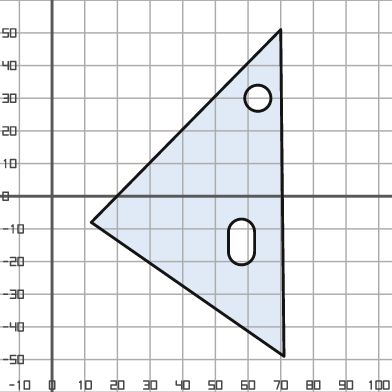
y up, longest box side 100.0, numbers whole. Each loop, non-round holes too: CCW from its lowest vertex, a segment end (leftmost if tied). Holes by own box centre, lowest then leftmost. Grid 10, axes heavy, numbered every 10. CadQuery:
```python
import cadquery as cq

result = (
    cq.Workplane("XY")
    .moveTo(71.0, -49.0)
    .lineTo(70.0, 51.0)
    .lineTo(12.0, -8.0)
    .close()
    .moveTo(54.0, -17.0)
    .threePointArc((58.0, -21.0), (62.0, -17.0))
    .lineTo(62.0, -11.0)
    .threePointArc((58.0, -7.0), (54.0, -11.0))
    .close()
    .moveTo(63.0, 30.0)
    .circle(4.0)
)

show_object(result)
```